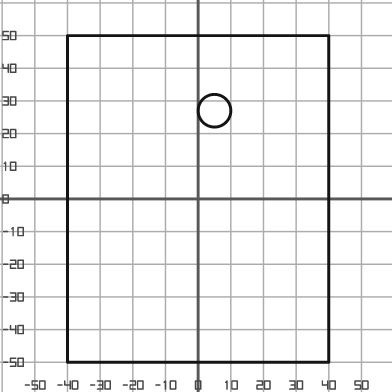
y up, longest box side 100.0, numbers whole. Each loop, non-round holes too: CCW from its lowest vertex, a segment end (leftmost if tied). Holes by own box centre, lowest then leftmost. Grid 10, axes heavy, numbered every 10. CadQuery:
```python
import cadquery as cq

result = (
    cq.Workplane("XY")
    .moveTo(-40.0, -50.0)
    .lineTo(40.0, -50.0)
    .lineTo(40.0, 50.0)
    .lineTo(-40.0, 50.0)
    .close()
    .moveTo(5.0, 27.0)
    .circle(5.0)
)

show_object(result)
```